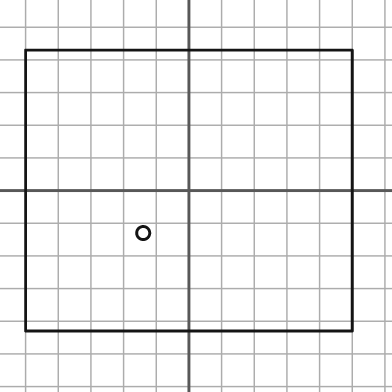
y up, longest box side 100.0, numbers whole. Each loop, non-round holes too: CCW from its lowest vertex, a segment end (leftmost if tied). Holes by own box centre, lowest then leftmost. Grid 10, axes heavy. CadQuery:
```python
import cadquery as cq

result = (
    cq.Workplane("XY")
    .moveTo(-50.0, -43.0)
    .lineTo(50.0, -43.0)
    .lineTo(50.0, 43.0)
    .lineTo(-50.0, 43.0)
    .close()
    .moveTo(-14.0, -13.0)
    .circle(2.0)
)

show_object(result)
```